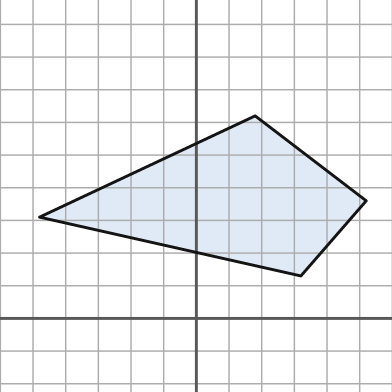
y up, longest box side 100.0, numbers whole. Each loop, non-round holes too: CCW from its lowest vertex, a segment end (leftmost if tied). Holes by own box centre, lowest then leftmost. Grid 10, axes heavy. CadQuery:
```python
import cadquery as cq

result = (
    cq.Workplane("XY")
    .moveTo(32.0, 13.0)
    .lineTo(52.0, 36.0)
    .lineTo(18.0, 62.0)
    .lineTo(-48.0, 31.0)
    .close()
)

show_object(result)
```